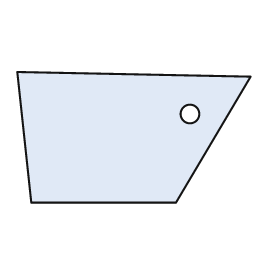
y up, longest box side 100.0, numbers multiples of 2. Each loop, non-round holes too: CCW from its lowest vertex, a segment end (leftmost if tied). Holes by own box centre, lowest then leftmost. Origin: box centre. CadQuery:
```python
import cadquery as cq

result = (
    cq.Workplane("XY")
    .moveTo(-44.0, -28.0)
    .lineTo(18.0, -28.0)
    .lineTo(50.0, 26.0)
    .lineTo(-50.0, 28.0)
    .close()
    .moveTo(24.0, 10.0)
    .circle(4.0)
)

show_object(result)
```